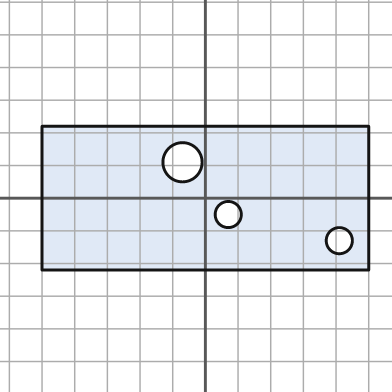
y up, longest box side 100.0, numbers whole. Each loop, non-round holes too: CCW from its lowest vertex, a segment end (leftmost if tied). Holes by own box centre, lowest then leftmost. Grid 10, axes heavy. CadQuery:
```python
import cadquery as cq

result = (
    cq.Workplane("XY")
    .moveTo(-50.0, -22.0)
    .lineTo(50.0, -22.0)
    .lineTo(50.0, 22.0)
    .lineTo(-50.0, 22.0)
    .close()
    .moveTo(41.0, -13.0)
    .circle(4.0)
    .moveTo(7.0, -5.0)
    .circle(4.0)
    .moveTo(-7.0, 11.0)
    .circle(6.0)
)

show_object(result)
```